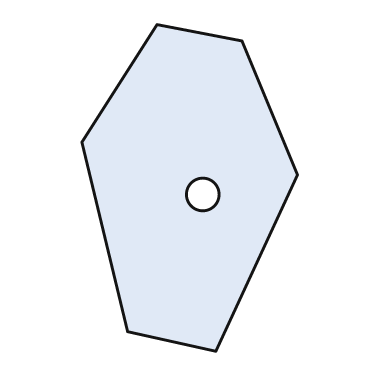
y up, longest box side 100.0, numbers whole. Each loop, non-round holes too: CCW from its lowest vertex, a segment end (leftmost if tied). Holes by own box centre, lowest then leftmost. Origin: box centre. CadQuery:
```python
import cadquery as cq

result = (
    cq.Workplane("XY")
    .moveTo(8.0, -50.0)
    .lineTo(33.0, 4.0)
    .lineTo(16.0, 45.0)
    .lineTo(-10.0, 50.0)
    .lineTo(-33.0, 14.0)
    .lineTo(-19.0, -44.0)
    .close()
    .moveTo(4.0, -2.0)
    .circle(5.0)
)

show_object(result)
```